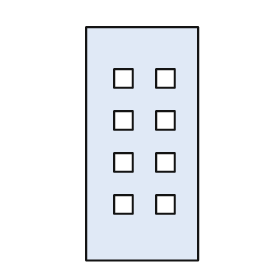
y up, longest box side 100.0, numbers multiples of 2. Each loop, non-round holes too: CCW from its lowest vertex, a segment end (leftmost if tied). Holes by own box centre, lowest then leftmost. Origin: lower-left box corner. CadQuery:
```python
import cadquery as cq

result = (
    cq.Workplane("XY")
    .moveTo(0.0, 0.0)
    .lineTo(48.0, 0.0)
    .lineTo(48.0, 100.0)
    .lineTo(0.0, 100.0)
    .close()
    .moveTo(12.0, 20.0)
    .lineTo(20.0, 20.0)
    .lineTo(20.0, 28.0)
    .lineTo(12.0, 28.0)
    .close()
    .moveTo(30.0, 20.0)
    .lineTo(38.0, 20.0)
    .lineTo(38.0, 28.0)
    .lineTo(30.0, 28.0)
    .close()
    .moveTo(12.0, 38.0)
    .lineTo(20.0, 38.0)
    .lineTo(20.0, 46.0)
    .lineTo(12.0, 46.0)
    .close()
    .moveTo(30.0, 38.0)
    .lineTo(38.0, 38.0)
    .lineTo(38.0, 46.0)
    .lineTo(30.0, 46.0)
    .close()
    .moveTo(12.0, 56.0)
    .lineTo(20.0, 56.0)
    .lineTo(20.0, 64.0)
    .lineTo(12.0, 64.0)
    .close()
    .moveTo(30.0, 56.0)
    .lineTo(38.0, 56.0)
    .lineTo(38.0, 64.0)
    .lineTo(30.0, 64.0)
    .close()
    .moveTo(12.0, 74.0)
    .lineTo(20.0, 74.0)
    .lineTo(20.0, 82.0)
    .lineTo(12.0, 82.0)
    .close()
    .moveTo(30.0, 74.0)
    .lineTo(38.0, 74.0)
    .lineTo(38.0, 82.0)
    .lineTo(30.0, 82.0)
    .close()
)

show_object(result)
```